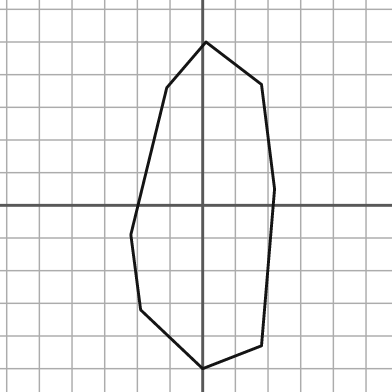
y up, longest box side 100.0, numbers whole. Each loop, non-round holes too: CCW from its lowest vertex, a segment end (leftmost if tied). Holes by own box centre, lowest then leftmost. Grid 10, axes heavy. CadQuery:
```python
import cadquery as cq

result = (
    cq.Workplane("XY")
    .moveTo(0.0, -50.0)
    .lineTo(18.0, -43.0)
    .lineTo(22.0, 5.0)
    .lineTo(18.0, 37.0)
    .lineTo(1.0, 50.0)
    .lineTo(-11.0, 36.0)
    .lineTo(-22.0, -9.0)
    .lineTo(-19.0, -32.0)
    .close()
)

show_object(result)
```